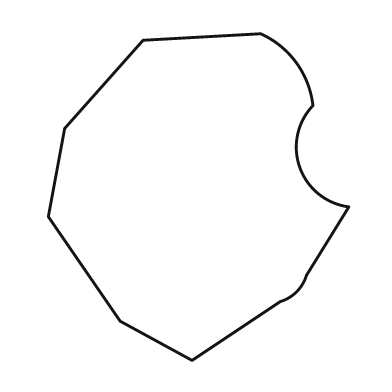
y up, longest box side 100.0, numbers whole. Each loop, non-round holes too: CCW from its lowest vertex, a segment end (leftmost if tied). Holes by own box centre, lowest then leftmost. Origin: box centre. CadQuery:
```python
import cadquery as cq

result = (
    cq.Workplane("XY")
    .moveTo(-2.0, -50.0)
    .lineTo(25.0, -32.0)
    .threePointArc((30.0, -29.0), (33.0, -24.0))
    .lineTo(46.0, -3.0)
    .threePointArc((31.0, 9.0), (35.0, 28.0))
    .threePointArc((30.0, 41.0), (19.0, 50.0))
    .lineTo(-17.0, 48.0)
    .lineTo(-41.0, 21.0)
    .lineTo(-46.0, -6.0)
    .lineTo(-24.0, -38.0)
    .close()
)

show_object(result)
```